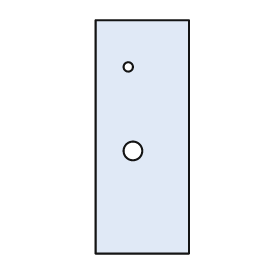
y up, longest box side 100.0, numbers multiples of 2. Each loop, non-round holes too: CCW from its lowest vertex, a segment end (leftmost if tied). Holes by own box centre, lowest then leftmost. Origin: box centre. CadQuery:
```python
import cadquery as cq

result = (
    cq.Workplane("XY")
    .moveTo(-20.0, -50.0)
    .lineTo(20.0, -50.0)
    .lineTo(20.0, 50.0)
    .lineTo(-20.0, 50.0)
    .close()
    .moveTo(-4.0, -6.0)
    .circle(4.0)
    .moveTo(-6.0, 30.0)
    .circle(2.0)
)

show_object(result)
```